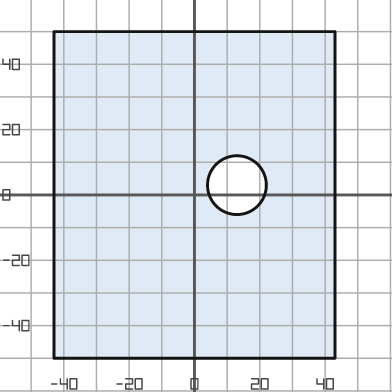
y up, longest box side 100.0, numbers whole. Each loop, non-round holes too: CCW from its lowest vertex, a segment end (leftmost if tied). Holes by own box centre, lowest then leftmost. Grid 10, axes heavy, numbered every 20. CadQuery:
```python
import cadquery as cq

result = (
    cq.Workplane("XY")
    .moveTo(-43.0, -50.0)
    .lineTo(43.0, -50.0)
    .lineTo(43.0, 50.0)
    .lineTo(-43.0, 50.0)
    .close()
    .moveTo(13.0, 3.0)
    .circle(9.0)
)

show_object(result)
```